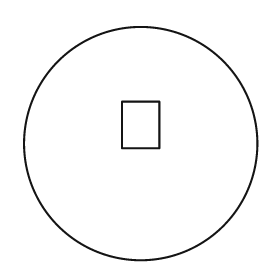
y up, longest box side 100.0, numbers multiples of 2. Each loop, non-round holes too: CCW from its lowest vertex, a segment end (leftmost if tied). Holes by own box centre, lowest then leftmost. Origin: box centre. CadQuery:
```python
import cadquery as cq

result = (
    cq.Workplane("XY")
    .moveTo(0.0, 0.0)
    .circle(50.0)
    .moveTo(-8.0, -2.0)
    .lineTo(8.0, -2.0)
    .lineTo(8.0, 18.0)
    .lineTo(-8.0, 18.0)
    .close()
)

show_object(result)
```